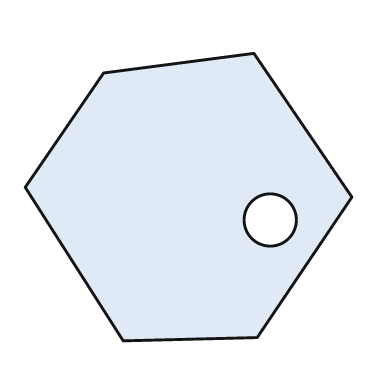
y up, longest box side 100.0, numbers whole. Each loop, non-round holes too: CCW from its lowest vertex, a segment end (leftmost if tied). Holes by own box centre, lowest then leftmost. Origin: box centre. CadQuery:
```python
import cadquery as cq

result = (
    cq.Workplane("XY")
    .moveTo(-20.0, -44.0)
    .lineTo(21.0, -43.0)
    .lineTo(50.0, 0.0)
    .lineTo(20.0, 44.0)
    .lineTo(-26.0, 38.0)
    .lineTo(-50.0, 3.0)
    .close()
    .moveTo(25.0, -7.0)
    .circle(8.0)
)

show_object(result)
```